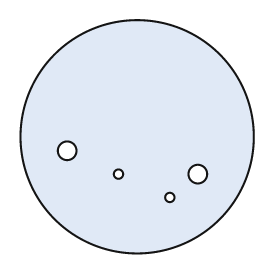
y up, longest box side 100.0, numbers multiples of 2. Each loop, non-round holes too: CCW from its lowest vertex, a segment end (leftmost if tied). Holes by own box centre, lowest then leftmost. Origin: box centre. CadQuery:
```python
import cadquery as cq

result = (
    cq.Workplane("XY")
    .moveTo(0.0, 0.0)
    .circle(50.0)
    .moveTo(14.0, -26.0)
    .circle(2.0)
    .moveTo(-8.0, -16.0)
    .circle(2.0)
    .moveTo(26.0, -16.0)
    .circle(4.0)
    .moveTo(-30.0, -6.0)
    .circle(4.0)
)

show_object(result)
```